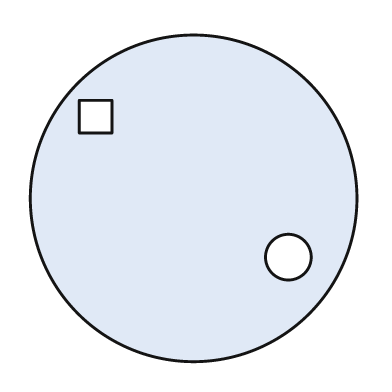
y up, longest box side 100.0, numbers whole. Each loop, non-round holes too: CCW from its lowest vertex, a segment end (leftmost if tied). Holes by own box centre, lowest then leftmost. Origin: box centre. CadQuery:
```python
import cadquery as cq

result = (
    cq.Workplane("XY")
    .moveTo(0.0, 0.0)
    .circle(50.0)
    .moveTo(29.0, -18.0)
    .circle(7.0)
    .moveTo(-35.0, 20.0)
    .lineTo(-25.0, 20.0)
    .lineTo(-25.0, 30.0)
    .lineTo(-35.0, 30.0)
    .close()
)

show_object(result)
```